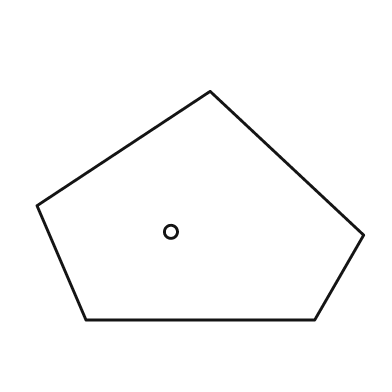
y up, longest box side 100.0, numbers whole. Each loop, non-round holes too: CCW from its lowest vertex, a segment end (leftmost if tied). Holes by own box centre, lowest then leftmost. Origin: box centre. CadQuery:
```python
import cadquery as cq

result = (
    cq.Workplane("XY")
    .moveTo(-35.0, -35.0)
    .lineTo(35.0, -35.0)
    .lineTo(50.0, -9.0)
    .lineTo(3.0, 35.0)
    .lineTo(-50.0, 0.0)
    .close()
    .moveTo(-9.0, -8.0)
    .circle(2.0)
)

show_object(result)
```